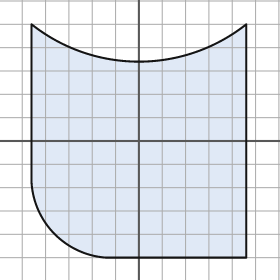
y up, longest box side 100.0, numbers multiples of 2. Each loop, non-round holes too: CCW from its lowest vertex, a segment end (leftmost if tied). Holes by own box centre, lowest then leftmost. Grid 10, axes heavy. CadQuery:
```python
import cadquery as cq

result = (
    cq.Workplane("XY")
    .moveTo(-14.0, -50.0)
    .lineTo(46.0, -50.0)
    .lineTo(46.0, 50.0)
    .threePointArc((0.0, 34.0), (-46.0, 50.0))
    .lineTo(-46.0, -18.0)
    .threePointArc((-36.0, -40.0), (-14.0, -50.0))
    .close()
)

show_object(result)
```